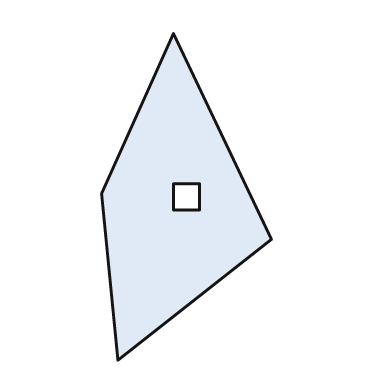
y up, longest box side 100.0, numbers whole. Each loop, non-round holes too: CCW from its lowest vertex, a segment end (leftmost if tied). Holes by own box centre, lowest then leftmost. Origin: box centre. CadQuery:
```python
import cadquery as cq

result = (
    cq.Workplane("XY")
    .moveTo(-21.0, -50.0)
    .lineTo(26.0, -13.0)
    .lineTo(-4.0, 50.0)
    .lineTo(-26.0, 1.0)
    .close()
    .moveTo(-4.0, -4.0)
    .lineTo(4.0, -4.0)
    .lineTo(4.0, 4.0)
    .lineTo(-4.0, 4.0)
    .close()
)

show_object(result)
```